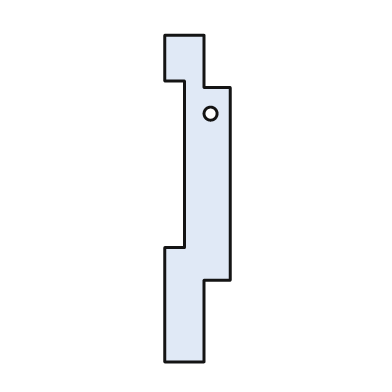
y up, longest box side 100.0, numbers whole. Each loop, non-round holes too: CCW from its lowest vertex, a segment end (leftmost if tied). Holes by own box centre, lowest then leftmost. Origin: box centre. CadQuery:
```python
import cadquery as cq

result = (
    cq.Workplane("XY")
    .moveTo(-10.0, -50.0)
    .lineTo(2.0, -50.0)
    .lineTo(2.0, -25.0)
    .lineTo(10.0, -25.0)
    .lineTo(10.0, 34.0)
    .lineTo(2.0, 34.0)
    .lineTo(2.0, 50.0)
    .lineTo(-10.0, 50.0)
    .lineTo(-10.0, 36.0)
    .lineTo(-4.0, 36.0)
    .lineTo(-4.0, -15.0)
    .lineTo(-10.0, -15.0)
    .close()
    .moveTo(4.0, 26.0)
    .circle(2.0)
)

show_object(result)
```